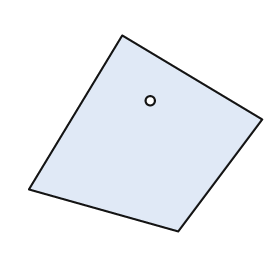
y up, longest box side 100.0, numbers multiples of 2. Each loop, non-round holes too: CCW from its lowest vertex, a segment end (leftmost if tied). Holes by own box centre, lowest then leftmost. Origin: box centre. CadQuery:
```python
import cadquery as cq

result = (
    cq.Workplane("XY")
    .moveTo(14.0, -42.0)
    .lineTo(50.0, 6.0)
    .lineTo(-10.0, 42.0)
    .lineTo(-50.0, -24.0)
    .close()
    .moveTo(2.0, 14.0)
    .circle(2.0)
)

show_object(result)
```